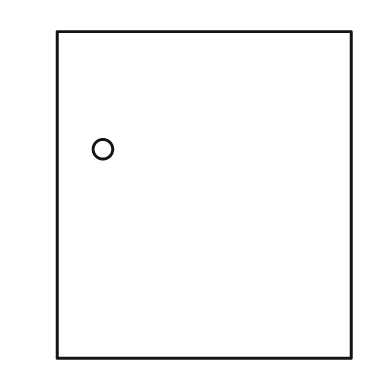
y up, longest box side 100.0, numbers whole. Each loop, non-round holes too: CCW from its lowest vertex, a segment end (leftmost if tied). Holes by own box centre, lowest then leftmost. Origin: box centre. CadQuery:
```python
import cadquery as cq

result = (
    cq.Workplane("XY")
    .moveTo(-45.0, -50.0)
    .lineTo(45.0, -50.0)
    .lineTo(45.0, 50.0)
    .lineTo(-45.0, 50.0)
    .close()
    .moveTo(-31.0, 14.0)
    .circle(3.0)
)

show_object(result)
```